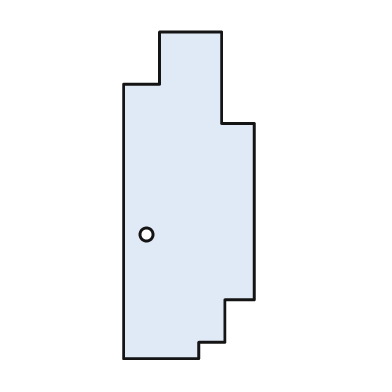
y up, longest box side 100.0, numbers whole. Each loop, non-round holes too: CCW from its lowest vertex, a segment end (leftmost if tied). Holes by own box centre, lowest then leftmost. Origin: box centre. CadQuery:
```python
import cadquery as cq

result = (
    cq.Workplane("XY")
    .moveTo(-20.0, -50.0)
    .lineTo(3.0, -50.0)
    .lineTo(3.0, -45.0)
    .lineTo(11.0, -45.0)
    .lineTo(11.0, -32.0)
    .lineTo(20.0, -32.0)
    .lineTo(20.0, 22.0)
    .lineTo(10.0, 22.0)
    .lineTo(10.0, 50.0)
    .lineTo(-9.0, 50.0)
    .lineTo(-9.0, 34.0)
    .lineTo(-20.0, 34.0)
    .close()
    .moveTo(-13.0, -12.0)
    .circle(2.0)
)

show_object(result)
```